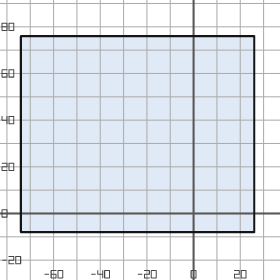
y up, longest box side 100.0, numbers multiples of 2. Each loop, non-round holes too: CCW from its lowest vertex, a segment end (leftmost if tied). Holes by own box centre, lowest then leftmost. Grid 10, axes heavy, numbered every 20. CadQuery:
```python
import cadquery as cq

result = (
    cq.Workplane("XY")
    .moveTo(-74.0, -8.0)
    .lineTo(26.0, -8.0)
    .lineTo(26.0, 76.0)
    .lineTo(-74.0, 76.0)
    .close()
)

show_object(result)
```